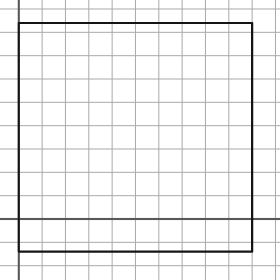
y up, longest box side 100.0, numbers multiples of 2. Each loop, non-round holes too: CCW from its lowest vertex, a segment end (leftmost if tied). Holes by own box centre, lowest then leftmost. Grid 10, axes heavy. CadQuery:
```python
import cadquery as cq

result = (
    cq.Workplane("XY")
    .moveTo(0.0, -14.0)
    .lineTo(100.0, -14.0)
    .lineTo(100.0, 84.0)
    .lineTo(0.0, 84.0)
    .close()
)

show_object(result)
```